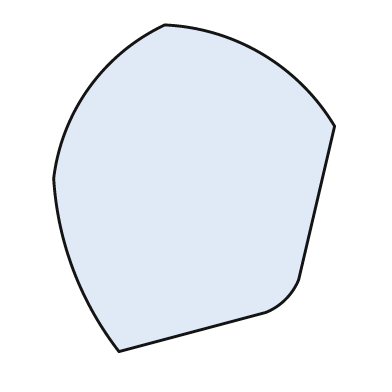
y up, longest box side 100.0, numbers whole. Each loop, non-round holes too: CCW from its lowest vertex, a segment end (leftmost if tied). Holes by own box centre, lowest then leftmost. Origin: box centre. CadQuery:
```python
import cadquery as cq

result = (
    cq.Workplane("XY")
    .moveTo(-23.0, -50.0)
    .lineTo(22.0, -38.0)
    .threePointArc((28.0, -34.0), (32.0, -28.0))
    .lineTo(43.0, 19.0)
    .threePointArc((21.0, 41.0), (-9.0, 50.0))
    .threePointArc((-32.0, 31.0), (-43.0, 3.0))
    .threePointArc((-37.0, -25.0), (-23.0, -50.0))
    .close()
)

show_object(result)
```